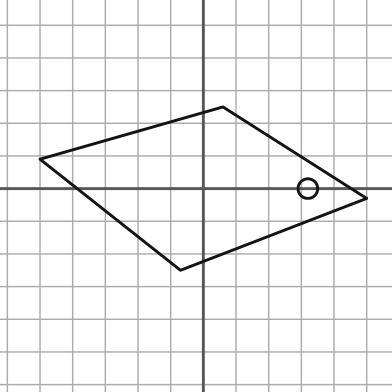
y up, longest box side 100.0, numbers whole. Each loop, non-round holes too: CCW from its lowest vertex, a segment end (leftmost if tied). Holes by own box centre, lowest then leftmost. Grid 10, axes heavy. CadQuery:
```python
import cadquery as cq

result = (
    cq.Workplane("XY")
    .moveTo(-7.0, -25.0)
    .lineTo(50.0, -3.0)
    .lineTo(6.0, 25.0)
    .lineTo(-50.0, 9.0)
    .close()
    .moveTo(32.0, 0.0)
    .circle(3.0)
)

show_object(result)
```